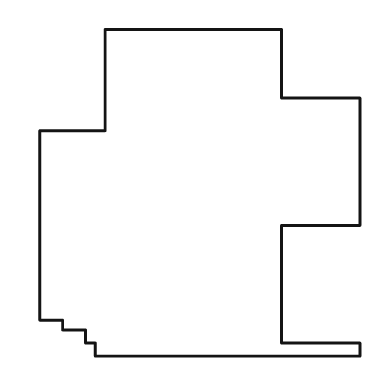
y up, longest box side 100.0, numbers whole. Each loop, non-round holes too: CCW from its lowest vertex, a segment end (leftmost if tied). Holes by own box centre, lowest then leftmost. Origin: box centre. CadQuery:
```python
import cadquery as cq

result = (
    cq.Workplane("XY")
    .moveTo(-32.0, -50.0)
    .lineTo(49.0, -50.0)
    .lineTo(49.0, -46.0)
    .lineTo(25.0, -46.0)
    .lineTo(25.0, -10.0)
    .lineTo(49.0, -10.0)
    .lineTo(49.0, 29.0)
    .lineTo(25.0, 29.0)
    .lineTo(25.0, 50.0)
    .lineTo(-29.0, 50.0)
    .lineTo(-29.0, 19.0)
    .lineTo(-49.0, 19.0)
    .lineTo(-49.0, -39.0)
    .lineTo(-42.0, -39.0)
    .lineTo(-42.0, -42.0)
    .lineTo(-35.0, -42.0)
    .lineTo(-35.0, -46.0)
    .lineTo(-32.0, -46.0)
    .close()
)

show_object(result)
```